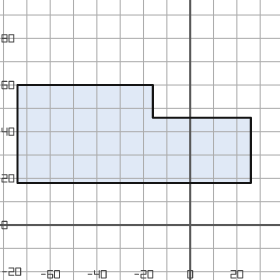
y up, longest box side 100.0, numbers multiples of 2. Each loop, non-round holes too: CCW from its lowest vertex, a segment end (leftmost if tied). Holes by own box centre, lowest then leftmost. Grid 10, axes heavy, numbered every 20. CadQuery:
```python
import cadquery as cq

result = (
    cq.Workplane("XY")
    .moveTo(-74.0, 18.0)
    .lineTo(26.0, 18.0)
    .lineTo(26.0, 46.0)
    .lineTo(-16.0, 46.0)
    .lineTo(-16.0, 60.0)
    .lineTo(-74.0, 60.0)
    .close()
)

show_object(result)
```